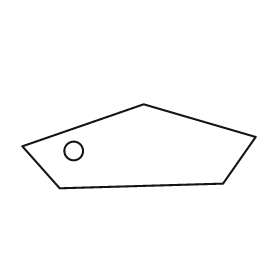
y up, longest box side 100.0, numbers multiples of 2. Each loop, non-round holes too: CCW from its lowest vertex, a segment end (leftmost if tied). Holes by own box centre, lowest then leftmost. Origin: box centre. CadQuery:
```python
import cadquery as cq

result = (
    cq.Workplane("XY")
    .moveTo(-34.0, -18.0)
    .lineTo(36.0, -16.0)
    .lineTo(50.0, 4.0)
    .lineTo(2.0, 18.0)
    .lineTo(-50.0, 0.0)
    .close()
    .moveTo(-28.0, -2.0)
    .circle(4.0)
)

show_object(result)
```